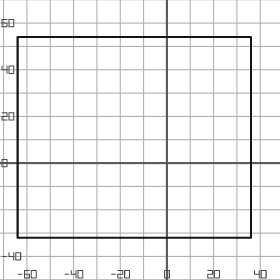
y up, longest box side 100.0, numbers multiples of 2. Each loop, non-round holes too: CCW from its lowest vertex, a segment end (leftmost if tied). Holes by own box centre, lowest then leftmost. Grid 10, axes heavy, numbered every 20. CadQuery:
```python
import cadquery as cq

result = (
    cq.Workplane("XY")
    .moveTo(-64.0, -32.0)
    .lineTo(36.0, -32.0)
    .lineTo(36.0, 54.0)
    .lineTo(-64.0, 54.0)
    .close()
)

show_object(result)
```